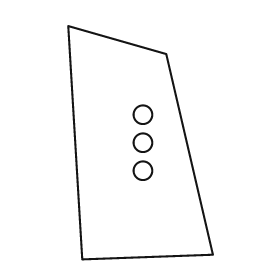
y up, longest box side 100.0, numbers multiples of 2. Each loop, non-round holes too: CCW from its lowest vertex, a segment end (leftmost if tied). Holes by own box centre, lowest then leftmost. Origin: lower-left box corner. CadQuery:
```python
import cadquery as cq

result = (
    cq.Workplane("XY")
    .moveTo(6.0, 0.0)
    .lineTo(62.0, 2.0)
    .lineTo(42.0, 88.0)
    .lineTo(0.0, 100.0)
    .close()
    .moveTo(32.0, 38.0)
    .circle(4.0)
    .moveTo(32.0, 50.0)
    .circle(4.0)
    .moveTo(32.0, 62.0)
    .circle(4.0)
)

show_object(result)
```